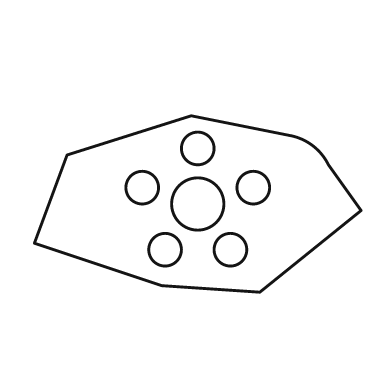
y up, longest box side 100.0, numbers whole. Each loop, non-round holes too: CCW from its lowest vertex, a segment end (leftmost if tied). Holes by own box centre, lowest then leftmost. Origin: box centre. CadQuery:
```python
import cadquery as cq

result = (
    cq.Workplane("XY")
    .moveTo(19.0, -27.0)
    .lineTo(50.0, -2.0)
    .lineTo(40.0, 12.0)
    .threePointArc((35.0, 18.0), (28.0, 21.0))
    .lineTo(-2.0, 27.0)
    .lineTo(-40.0, 15.0)
    .lineTo(-50.0, -12.0)
    .lineTo(-11.0, -25.0)
    .close()
    .moveTo(-10.0, -14.0)
    .circle(5.0)
    .moveTo(10.0, -14.0)
    .circle(5.0)
    .moveTo(0.0, 0.0)
    .circle(8.0)
    .moveTo(-17.0, 5.0)
    .circle(5.0)
    .moveTo(17.0, 5.0)
    .circle(5.0)
    .moveTo(0.0, 17.0)
    .circle(5.0)
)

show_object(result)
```